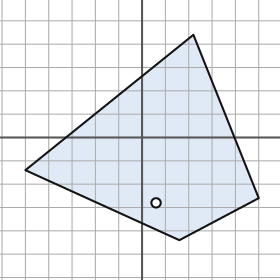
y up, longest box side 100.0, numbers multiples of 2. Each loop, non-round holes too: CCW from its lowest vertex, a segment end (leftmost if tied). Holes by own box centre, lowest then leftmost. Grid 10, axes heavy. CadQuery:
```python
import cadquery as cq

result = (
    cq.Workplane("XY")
    .moveTo(16.0, -44.0)
    .lineTo(50.0, -26.0)
    .lineTo(22.0, 44.0)
    .lineTo(-50.0, -14.0)
    .close()
    .moveTo(6.0, -28.0)
    .circle(2.0)
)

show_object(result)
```